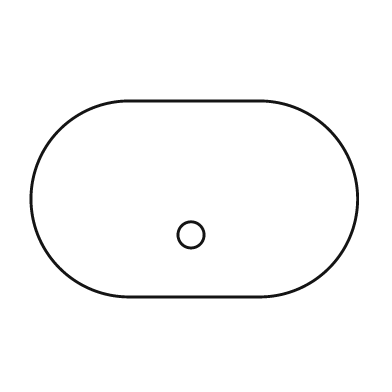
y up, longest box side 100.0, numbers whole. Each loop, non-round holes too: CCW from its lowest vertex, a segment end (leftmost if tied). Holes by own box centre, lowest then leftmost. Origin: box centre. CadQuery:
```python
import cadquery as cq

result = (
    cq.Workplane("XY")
    .moveTo(-20.0, -30.0)
    .lineTo(20.0, -30.0)
    .threePointArc((50.0, 0.0), (20.0, 30.0))
    .lineTo(-20.0, 30.0)
    .threePointArc((-50.0, 0.0), (-20.0, -30.0))
    .close()
    .moveTo(-1.0, -11.0)
    .circle(4.0)
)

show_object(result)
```